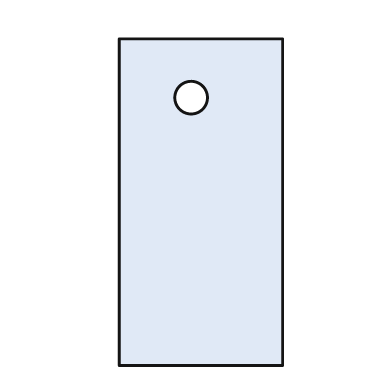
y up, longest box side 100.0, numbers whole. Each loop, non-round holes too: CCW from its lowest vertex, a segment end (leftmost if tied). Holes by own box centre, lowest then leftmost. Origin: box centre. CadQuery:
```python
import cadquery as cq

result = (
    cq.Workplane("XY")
    .moveTo(-25.0, -50.0)
    .lineTo(25.0, -50.0)
    .lineTo(25.0, 50.0)
    .lineTo(-25.0, 50.0)
    .close()
    .moveTo(-3.0, 32.0)
    .circle(5.0)
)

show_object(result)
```